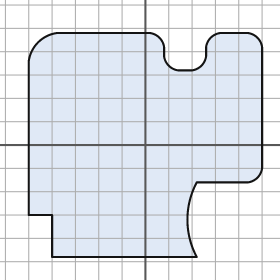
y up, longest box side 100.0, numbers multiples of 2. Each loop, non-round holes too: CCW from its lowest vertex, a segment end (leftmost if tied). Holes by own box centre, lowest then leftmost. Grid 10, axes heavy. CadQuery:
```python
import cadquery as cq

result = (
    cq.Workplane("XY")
    .moveTo(-40.0, -48.0)
    .lineTo(22.0, -48.0)
    .threePointArc((18.0, -32.0), (22.0, -16.0))
    .lineTo(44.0, -16.0)
    .threePointArc((48.0, -14.0), (50.0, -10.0))
    .lineTo(50.0, 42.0)
    .threePointArc((48.0, 46.0), (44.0, 48.0))
    .lineTo(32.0, 48.0)
    .threePointArc((28.0, 46.0), (26.0, 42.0))
    .lineTo(26.0, 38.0)
    .threePointArc((24.0, 34.0), (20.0, 32.0))
    .lineTo(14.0, 32.0)
    .threePointArc((10.0, 34.0), (8.0, 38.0))
    .lineTo(8.0, 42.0)
    .threePointArc((6.0, 46.0), (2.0, 48.0))
    .lineTo(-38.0, 48.0)
    .threePointArc((-46.0, 44.0), (-50.0, 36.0))
    .lineTo(-50.0, -30.0)
    .lineTo(-40.0, -30.0)
    .close()
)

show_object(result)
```